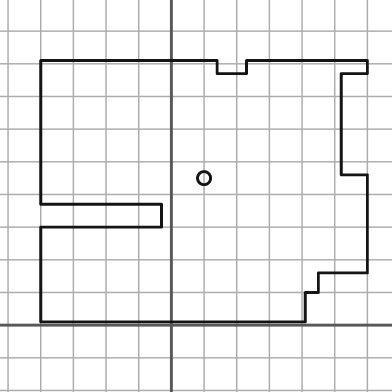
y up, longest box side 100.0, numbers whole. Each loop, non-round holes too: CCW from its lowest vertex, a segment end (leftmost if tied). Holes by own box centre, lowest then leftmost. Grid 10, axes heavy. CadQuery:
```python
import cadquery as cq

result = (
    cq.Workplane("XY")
    .moveTo(-40.0, 1.0)
    .lineTo(41.0, 1.0)
    .lineTo(41.0, 10.0)
    .lineTo(45.0, 10.0)
    .lineTo(45.0, 16.0)
    .lineTo(60.0, 16.0)
    .lineTo(60.0, 46.0)
    .lineTo(52.0, 46.0)
    .lineTo(52.0, 77.0)
    .lineTo(60.0, 77.0)
    .lineTo(60.0, 81.0)
    .lineTo(23.0, 81.0)
    .lineTo(23.0, 77.0)
    .lineTo(14.0, 77.0)
    .lineTo(14.0, 81.0)
    .lineTo(-40.0, 81.0)
    .lineTo(-40.0, 37.0)
    .lineTo(-3.0, 37.0)
    .lineTo(-3.0, 30.0)
    .lineTo(-40.0, 30.0)
    .close()
    .moveTo(10.0, 45.0)
    .circle(2.0)
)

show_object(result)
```